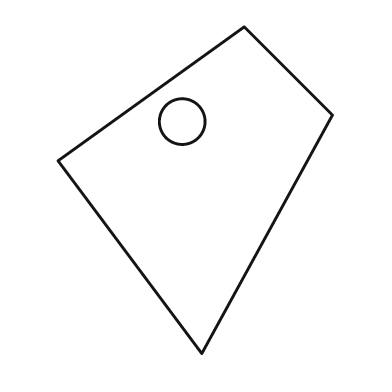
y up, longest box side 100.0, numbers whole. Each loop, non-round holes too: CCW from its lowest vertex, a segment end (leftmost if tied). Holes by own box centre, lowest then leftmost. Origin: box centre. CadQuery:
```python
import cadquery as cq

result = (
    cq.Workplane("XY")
    .moveTo(2.0, -50.0)
    .lineTo(42.0, 23.0)
    .lineTo(15.0, 50.0)
    .lineTo(-42.0, 9.0)
    .close()
    .moveTo(-4.0, 21.0)
    .circle(7.0)
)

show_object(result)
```